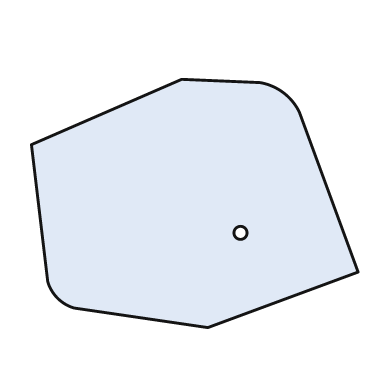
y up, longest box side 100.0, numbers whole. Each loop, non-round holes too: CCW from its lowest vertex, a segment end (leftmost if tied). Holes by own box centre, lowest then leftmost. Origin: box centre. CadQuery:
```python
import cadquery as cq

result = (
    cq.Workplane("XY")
    .moveTo(4.0, -38.0)
    .lineTo(50.0, -21.0)
    .lineTo(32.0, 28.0)
    .threePointArc((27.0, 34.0), (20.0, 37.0))
    .lineTo(-4.0, 38.0)
    .lineTo(-50.0, 18.0)
    .lineTo(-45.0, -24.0)
    .threePointArc((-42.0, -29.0), (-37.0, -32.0))
    .close()
    .moveTo(14.0, -9.0)
    .circle(2.0)
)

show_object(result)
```